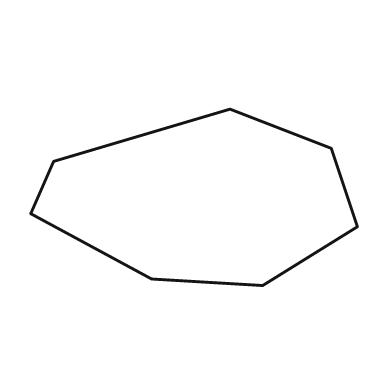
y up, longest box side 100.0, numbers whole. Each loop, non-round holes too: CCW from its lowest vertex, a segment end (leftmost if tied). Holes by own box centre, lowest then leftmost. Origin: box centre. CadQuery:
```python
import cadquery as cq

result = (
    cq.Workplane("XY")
    .moveTo(21.0, -27.0)
    .lineTo(50.0, -9.0)
    .lineTo(42.0, 15.0)
    .lineTo(11.0, 27.0)
    .lineTo(-43.0, 11.0)
    .lineTo(-50.0, -5.0)
    .lineTo(-13.0, -25.0)
    .close()
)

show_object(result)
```